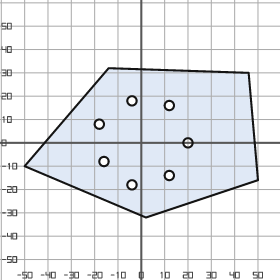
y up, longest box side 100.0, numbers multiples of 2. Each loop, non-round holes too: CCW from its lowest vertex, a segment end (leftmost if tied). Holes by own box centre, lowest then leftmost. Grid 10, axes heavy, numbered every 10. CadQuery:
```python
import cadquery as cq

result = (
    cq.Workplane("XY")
    .moveTo(2.0, -32.0)
    .lineTo(50.0, -16.0)
    .lineTo(46.0, 30.0)
    .lineTo(-14.0, 32.0)
    .lineTo(-50.0, -10.0)
    .close()
    .moveTo(-4.0, -18.0)
    .circle(2.0)
    .moveTo(12.0, -14.0)
    .circle(2.0)
    .moveTo(-16.0, -8.0)
    .circle(2.0)
    .moveTo(20.0, 0.0)
    .circle(2.0)
    .moveTo(-18.0, 8.0)
    .circle(2.0)
    .moveTo(12.0, 16.0)
    .circle(2.0)
    .moveTo(-4.0, 18.0)
    .circle(2.0)
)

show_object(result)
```